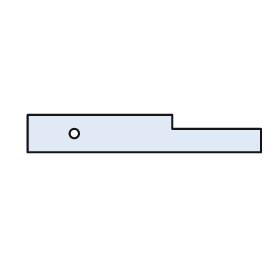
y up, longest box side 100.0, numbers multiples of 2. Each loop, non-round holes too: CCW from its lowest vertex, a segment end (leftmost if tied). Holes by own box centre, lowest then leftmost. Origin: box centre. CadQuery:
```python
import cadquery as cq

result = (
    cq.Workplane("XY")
    .moveTo(-50.0, -8.0)
    .lineTo(50.0, -8.0)
    .lineTo(50.0, 2.0)
    .lineTo(12.0, 2.0)
    .lineTo(12.0, 8.0)
    .lineTo(-50.0, 8.0)
    .close()
    .moveTo(-30.0, 0.0)
    .circle(2.0)
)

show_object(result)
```